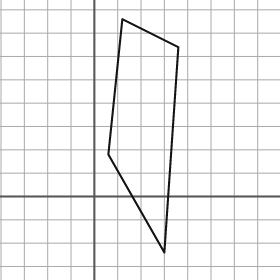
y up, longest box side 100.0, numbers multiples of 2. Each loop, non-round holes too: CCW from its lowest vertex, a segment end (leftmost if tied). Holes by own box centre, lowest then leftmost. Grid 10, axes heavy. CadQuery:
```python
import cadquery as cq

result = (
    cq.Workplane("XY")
    .moveTo(30.0, -24.0)
    .lineTo(36.0, 64.0)
    .lineTo(12.0, 76.0)
    .lineTo(6.0, 18.0)
    .close()
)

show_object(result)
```